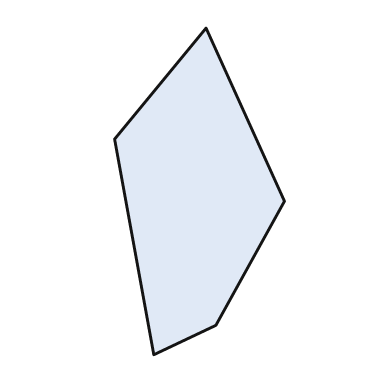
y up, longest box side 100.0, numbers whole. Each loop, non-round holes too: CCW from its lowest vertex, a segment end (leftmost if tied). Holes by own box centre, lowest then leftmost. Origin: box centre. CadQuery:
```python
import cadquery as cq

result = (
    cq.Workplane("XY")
    .moveTo(-14.0, -50.0)
    .lineTo(5.0, -41.0)
    .lineTo(26.0, -3.0)
    .lineTo(2.0, 50.0)
    .lineTo(-26.0, 16.0)
    .close()
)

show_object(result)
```